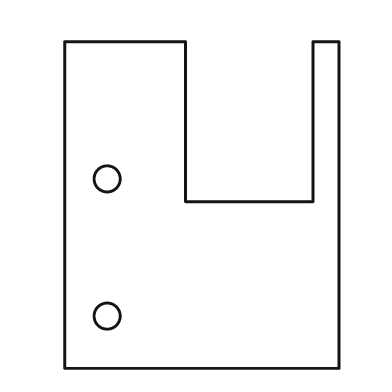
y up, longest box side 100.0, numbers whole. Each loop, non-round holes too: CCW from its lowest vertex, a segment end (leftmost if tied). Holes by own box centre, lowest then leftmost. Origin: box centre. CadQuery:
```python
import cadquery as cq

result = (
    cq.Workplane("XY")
    .moveTo(-42.0, -50.0)
    .lineTo(42.0, -50.0)
    .lineTo(42.0, 50.0)
    .lineTo(34.0, 50.0)
    .lineTo(34.0, 1.0)
    .lineTo(-5.0, 1.0)
    .lineTo(-5.0, 50.0)
    .lineTo(-42.0, 50.0)
    .close()
    .moveTo(-29.0, -34.0)
    .circle(4.0)
    .moveTo(-29.0, 8.0)
    .circle(4.0)
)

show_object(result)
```